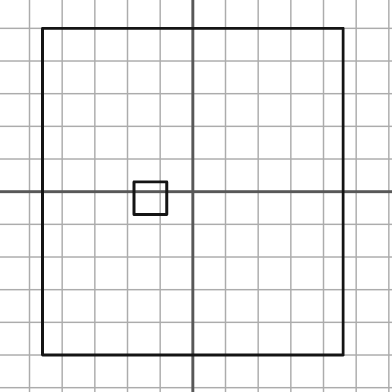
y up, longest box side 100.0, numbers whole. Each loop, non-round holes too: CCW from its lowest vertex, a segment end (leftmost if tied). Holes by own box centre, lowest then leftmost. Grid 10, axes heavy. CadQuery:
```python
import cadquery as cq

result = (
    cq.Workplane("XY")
    .moveTo(-46.0, -50.0)
    .lineTo(46.0, -50.0)
    .lineTo(46.0, 50.0)
    .lineTo(-46.0, 50.0)
    .close()
    .moveTo(-18.0, -7.0)
    .lineTo(-8.0, -7.0)
    .lineTo(-8.0, 3.0)
    .lineTo(-18.0, 3.0)
    .close()
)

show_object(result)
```